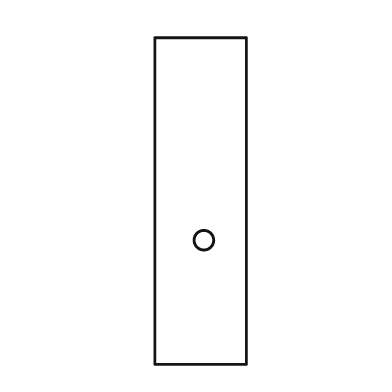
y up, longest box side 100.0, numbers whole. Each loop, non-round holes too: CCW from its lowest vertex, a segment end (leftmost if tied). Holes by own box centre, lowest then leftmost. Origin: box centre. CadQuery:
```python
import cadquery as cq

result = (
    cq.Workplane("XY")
    .moveTo(-14.0, -50.0)
    .lineTo(14.0, -50.0)
    .lineTo(14.0, 50.0)
    .lineTo(-14.0, 50.0)
    .close()
    .moveTo(1.0, -12.0)
    .circle(3.0)
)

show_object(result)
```